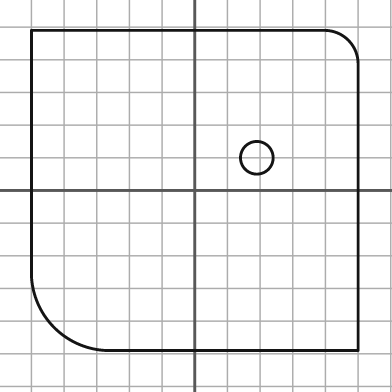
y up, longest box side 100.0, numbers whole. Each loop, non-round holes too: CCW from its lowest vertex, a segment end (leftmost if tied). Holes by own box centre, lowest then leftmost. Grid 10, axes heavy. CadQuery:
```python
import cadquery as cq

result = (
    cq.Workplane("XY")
    .moveTo(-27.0, -49.0)
    .lineTo(50.0, -49.0)
    .lineTo(50.0, 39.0)
    .threePointArc((47.0, 46.0), (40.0, 49.0))
    .lineTo(-50.0, 49.0)
    .lineTo(-50.0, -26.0)
    .threePointArc((-43.0, -42.0), (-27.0, -49.0))
    .close()
    .moveTo(19.0, 10.0)
    .circle(5.0)
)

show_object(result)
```